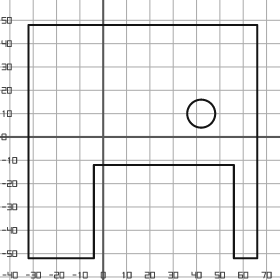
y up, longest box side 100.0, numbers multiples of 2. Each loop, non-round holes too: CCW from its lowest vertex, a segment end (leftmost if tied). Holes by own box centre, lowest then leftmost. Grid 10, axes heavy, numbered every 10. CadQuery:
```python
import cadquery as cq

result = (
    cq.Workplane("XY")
    .moveTo(-32.0, -52.0)
    .lineTo(-4.0, -52.0)
    .lineTo(-4.0, -12.0)
    .lineTo(56.0, -12.0)
    .lineTo(56.0, -52.0)
    .lineTo(66.0, -52.0)
    .lineTo(66.0, 48.0)
    .lineTo(-32.0, 48.0)
    .close()
    .moveTo(42.0, 10.0)
    .circle(6.0)
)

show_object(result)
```